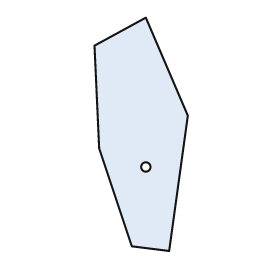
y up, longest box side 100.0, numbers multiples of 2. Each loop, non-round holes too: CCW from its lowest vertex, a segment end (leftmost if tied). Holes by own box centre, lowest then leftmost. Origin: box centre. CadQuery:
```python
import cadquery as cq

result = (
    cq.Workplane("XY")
    .moveTo(12.0, -50.0)
    .lineTo(20.0, 8.0)
    .lineTo(2.0, 50.0)
    .lineTo(-20.0, 38.0)
    .lineTo(-18.0, -6.0)
    .lineTo(-4.0, -48.0)
    .close()
    .moveTo(2.0, -14.0)
    .circle(2.0)
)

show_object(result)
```